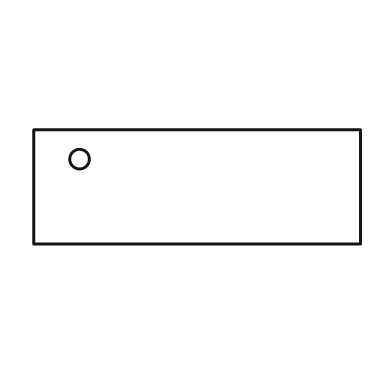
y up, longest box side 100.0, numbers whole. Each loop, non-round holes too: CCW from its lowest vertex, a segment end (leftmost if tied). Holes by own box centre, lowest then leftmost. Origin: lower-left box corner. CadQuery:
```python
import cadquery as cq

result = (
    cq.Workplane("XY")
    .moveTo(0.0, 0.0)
    .lineTo(100.0, 0.0)
    .lineTo(100.0, 35.0)
    .lineTo(0.0, 35.0)
    .close()
    .moveTo(14.0, 26.0)
    .circle(3.0)
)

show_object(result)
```